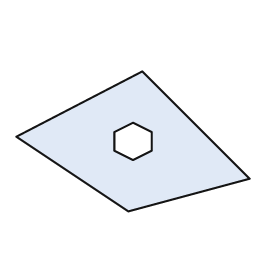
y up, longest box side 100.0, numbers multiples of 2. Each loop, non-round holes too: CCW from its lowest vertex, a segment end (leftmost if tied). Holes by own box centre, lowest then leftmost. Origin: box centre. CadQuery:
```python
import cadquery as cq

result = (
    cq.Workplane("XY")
    .moveTo(-2.0, -30.0)
    .lineTo(50.0, -16.0)
    .lineTo(4.0, 30.0)
    .lineTo(-50.0, 2.0)
    .close()
    .moveTo(0.0, -8.0)
    .lineTo(8.0, -4.0)
    .lineTo(8.0, 4.0)
    .lineTo(0.0, 8.0)
    .lineTo(-8.0, 4.0)
    .lineTo(-8.0, -4.0)
    .close()
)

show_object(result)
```